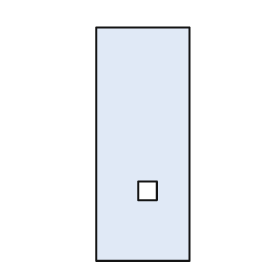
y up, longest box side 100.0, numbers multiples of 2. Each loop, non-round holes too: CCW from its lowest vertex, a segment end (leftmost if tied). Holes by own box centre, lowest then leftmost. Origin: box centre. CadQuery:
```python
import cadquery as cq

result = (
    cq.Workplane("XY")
    .moveTo(-20.0, -50.0)
    .lineTo(20.0, -50.0)
    .lineTo(20.0, 50.0)
    .lineTo(-20.0, 50.0)
    .close()
    .moveTo(-2.0, -24.0)
    .lineTo(6.0, -24.0)
    .lineTo(6.0, -16.0)
    .lineTo(-2.0, -16.0)
    .close()
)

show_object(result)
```